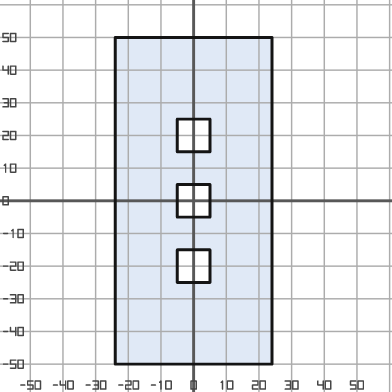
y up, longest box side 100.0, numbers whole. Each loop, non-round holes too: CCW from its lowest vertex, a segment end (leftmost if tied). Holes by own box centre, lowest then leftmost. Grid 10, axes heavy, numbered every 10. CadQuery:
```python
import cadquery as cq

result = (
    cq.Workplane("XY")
    .moveTo(-24.0, -50.0)
    .lineTo(24.0, -50.0)
    .lineTo(24.0, 50.0)
    .lineTo(-24.0, 50.0)
    .close()
    .moveTo(-5.0, -25.0)
    .lineTo(5.0, -25.0)
    .lineTo(5.0, -15.0)
    .lineTo(-5.0, -15.0)
    .close()
    .moveTo(-5.0, -5.0)
    .lineTo(5.0, -5.0)
    .lineTo(5.0, 5.0)
    .lineTo(-5.0, 5.0)
    .close()
    .moveTo(-5.0, 15.0)
    .lineTo(5.0, 15.0)
    .lineTo(5.0, 25.0)
    .lineTo(-5.0, 25.0)
    .close()
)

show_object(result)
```